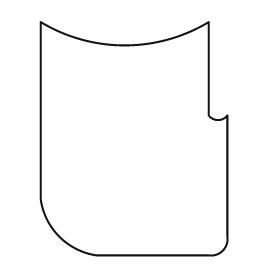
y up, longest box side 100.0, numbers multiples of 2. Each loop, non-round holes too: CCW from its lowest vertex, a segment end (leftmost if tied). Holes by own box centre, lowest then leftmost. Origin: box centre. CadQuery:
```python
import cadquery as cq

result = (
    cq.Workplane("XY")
    .moveTo(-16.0, -50.0)
    .lineTo(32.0, -50.0)
    .threePointArc((38.0, -48.0), (40.0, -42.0))
    .lineTo(40.0, 10.0)
    .threePointArc((36.0, 8.0), (32.0, 10.0))
    .lineTo(32.0, 50.0)
    .threePointArc((-4.0, 40.0), (-40.0, 50.0))
    .lineTo(-40.0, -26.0)
    .threePointArc((-32.0, -42.0), (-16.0, -50.0))
    .close()
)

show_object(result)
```